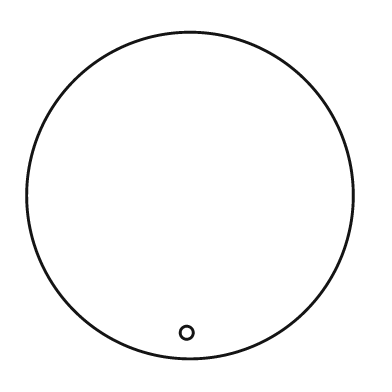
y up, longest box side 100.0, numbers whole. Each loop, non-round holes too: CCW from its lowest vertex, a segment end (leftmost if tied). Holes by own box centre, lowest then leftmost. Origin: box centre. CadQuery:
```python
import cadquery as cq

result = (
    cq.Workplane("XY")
    .moveTo(0.0, 0.0)
    .circle(50.0)
    .moveTo(-1.0, -42.0)
    .circle(2.0)
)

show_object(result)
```